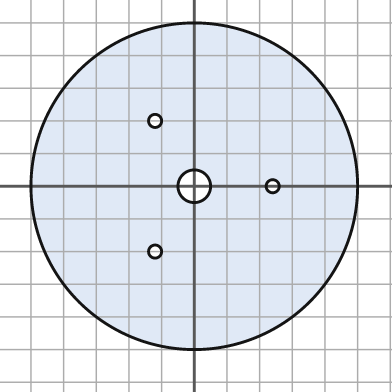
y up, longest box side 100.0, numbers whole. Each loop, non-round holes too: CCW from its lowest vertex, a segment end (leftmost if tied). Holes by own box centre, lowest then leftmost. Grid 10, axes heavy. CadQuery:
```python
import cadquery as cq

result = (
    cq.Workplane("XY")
    .moveTo(0.0, 0.0)
    .circle(50.0)
    .moveTo(-12.0, -20.0)
    .circle(2.0)
    .moveTo(0.0, 0.0)
    .circle(5.0)
    .moveTo(24.0, 0.0)
    .circle(2.0)
    .moveTo(-12.0, 20.0)
    .circle(2.0)
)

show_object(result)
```